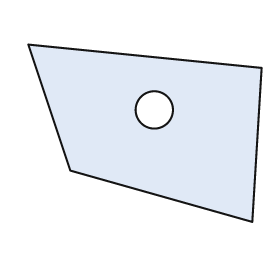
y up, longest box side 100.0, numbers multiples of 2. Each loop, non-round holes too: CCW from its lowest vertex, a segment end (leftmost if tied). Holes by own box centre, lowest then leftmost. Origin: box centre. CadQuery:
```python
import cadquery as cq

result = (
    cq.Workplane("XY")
    .moveTo(46.0, -38.0)
    .lineTo(50.0, 28.0)
    .lineTo(-50.0, 38.0)
    .lineTo(-32.0, -16.0)
    .close()
    .moveTo(4.0, 10.0)
    .circle(8.0)
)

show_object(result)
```